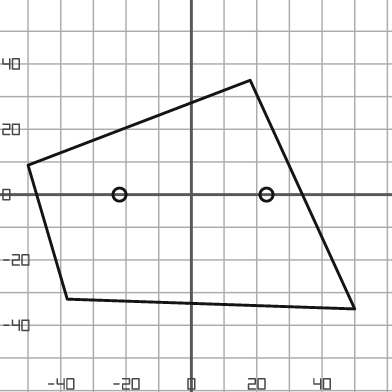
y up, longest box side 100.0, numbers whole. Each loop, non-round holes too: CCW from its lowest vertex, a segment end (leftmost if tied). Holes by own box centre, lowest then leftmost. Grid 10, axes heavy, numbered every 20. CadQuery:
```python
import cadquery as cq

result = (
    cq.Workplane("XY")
    .moveTo(50.0, -35.0)
    .lineTo(18.0, 35.0)
    .lineTo(-50.0, 9.0)
    .lineTo(-38.0, -32.0)
    .close()
    .moveTo(-22.0, 0.0)
    .circle(2.0)
    .moveTo(23.0, 0.0)
    .circle(2.0)
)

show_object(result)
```